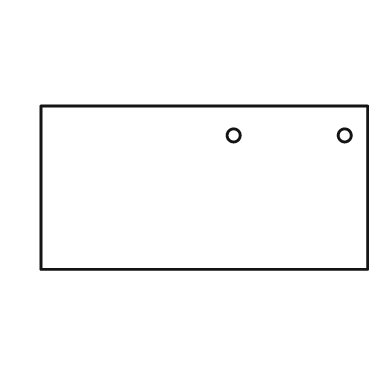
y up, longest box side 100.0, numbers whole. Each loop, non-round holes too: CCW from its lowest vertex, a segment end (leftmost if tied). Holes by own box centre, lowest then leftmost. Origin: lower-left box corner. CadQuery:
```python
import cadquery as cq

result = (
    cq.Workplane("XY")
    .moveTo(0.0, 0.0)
    .lineTo(100.0, 0.0)
    .lineTo(100.0, 50.0)
    .lineTo(0.0, 50.0)
    .close()
    .moveTo(59.0, 41.0)
    .circle(2.0)
    .moveTo(93.0, 41.0)
    .circle(2.0)
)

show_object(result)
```